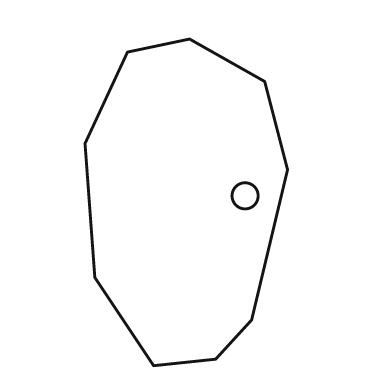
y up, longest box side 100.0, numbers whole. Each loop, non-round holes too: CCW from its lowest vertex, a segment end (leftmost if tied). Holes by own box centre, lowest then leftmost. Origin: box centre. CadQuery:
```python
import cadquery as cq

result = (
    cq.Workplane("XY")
    .moveTo(-10.0, -50.0)
    .lineTo(9.0, -48.0)
    .lineTo(20.0, -36.0)
    .lineTo(31.0, 10.0)
    .lineTo(24.0, 37.0)
    .lineTo(1.0, 50.0)
    .lineTo(-18.0, 46.0)
    .lineTo(-31.0, 18.0)
    .lineTo(-28.0, -23.0)
    .close()
    .moveTo(18.0, 2.0)
    .circle(4.0)
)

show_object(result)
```